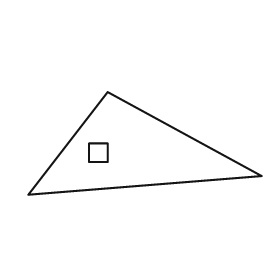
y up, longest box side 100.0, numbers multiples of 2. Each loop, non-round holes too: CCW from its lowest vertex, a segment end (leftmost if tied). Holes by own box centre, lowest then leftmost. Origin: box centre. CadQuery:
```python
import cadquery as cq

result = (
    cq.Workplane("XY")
    .moveTo(-50.0, -22.0)
    .lineTo(50.0, -14.0)
    .lineTo(-16.0, 22.0)
    .close()
    .moveTo(-24.0, -8.0)
    .lineTo(-16.0, -8.0)
    .lineTo(-16.0, 0.0)
    .lineTo(-24.0, 0.0)
    .close()
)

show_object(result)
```